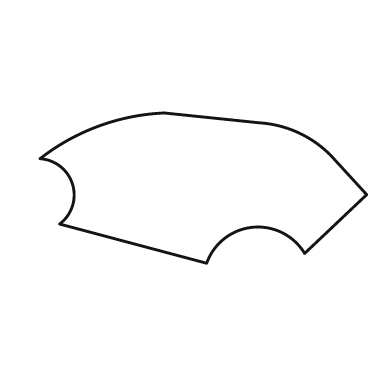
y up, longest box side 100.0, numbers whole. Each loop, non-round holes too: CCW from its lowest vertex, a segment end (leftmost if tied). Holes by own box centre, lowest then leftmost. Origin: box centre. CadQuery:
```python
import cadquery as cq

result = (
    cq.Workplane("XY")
    .moveTo(1.0, -23.0)
    .threePointArc((15.0, -12.0), (31.0, -20.0))
    .lineTo(50.0, -2.0)
    .lineTo(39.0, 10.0)
    .threePointArc((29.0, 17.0), (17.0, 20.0))
    .lineTo(-12.0, 23.0)
    .threePointArc((-32.0, 19.0), (-50.0, 9.0))
    .threePointArc((-40.0, 1.0), (-44.0, -11.0))
    .close()
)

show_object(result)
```